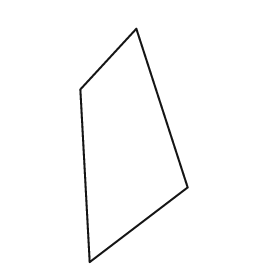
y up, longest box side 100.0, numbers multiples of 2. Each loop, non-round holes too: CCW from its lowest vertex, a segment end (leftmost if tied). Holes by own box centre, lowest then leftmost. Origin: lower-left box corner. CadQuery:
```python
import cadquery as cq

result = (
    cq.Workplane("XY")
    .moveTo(4.0, 0.0)
    .lineTo(46.0, 32.0)
    .lineTo(24.0, 100.0)
    .lineTo(0.0, 74.0)
    .close()
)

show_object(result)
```